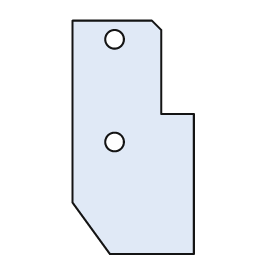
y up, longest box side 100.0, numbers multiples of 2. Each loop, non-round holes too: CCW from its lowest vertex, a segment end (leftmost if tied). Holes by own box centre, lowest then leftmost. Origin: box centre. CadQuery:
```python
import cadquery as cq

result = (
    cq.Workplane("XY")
    .moveTo(-10.0, -50.0)
    .lineTo(26.0, -50.0)
    .lineTo(26.0, 10.0)
    .lineTo(12.0, 10.0)
    .lineTo(12.0, 46.0)
    .lineTo(8.0, 50.0)
    .lineTo(-26.0, 50.0)
    .lineTo(-26.0, -28.0)
    .close()
    .moveTo(-8.0, -2.0)
    .circle(4.0)
    .moveTo(-8.0, 42.0)
    .circle(4.0)
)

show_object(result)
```